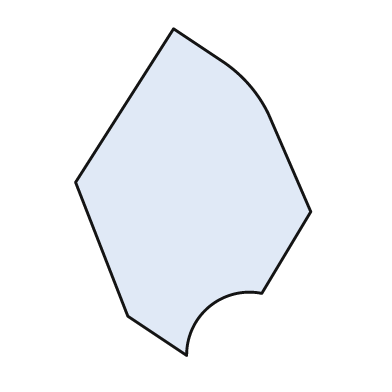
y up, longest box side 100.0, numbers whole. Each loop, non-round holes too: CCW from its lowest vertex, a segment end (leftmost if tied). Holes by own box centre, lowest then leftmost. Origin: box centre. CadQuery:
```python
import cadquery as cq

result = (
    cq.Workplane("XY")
    .moveTo(-2.0, -50.0)
    .threePointArc((5.0, -35.0), (21.0, -31.0))
    .lineTo(36.0, -6.0)
    .lineTo(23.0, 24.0)
    .threePointArc((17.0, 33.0), (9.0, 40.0))
    .lineTo(-6.0, 50.0)
    .lineTo(-36.0, 3.0)
    .lineTo(-20.0, -38.0)
    .close()
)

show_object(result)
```